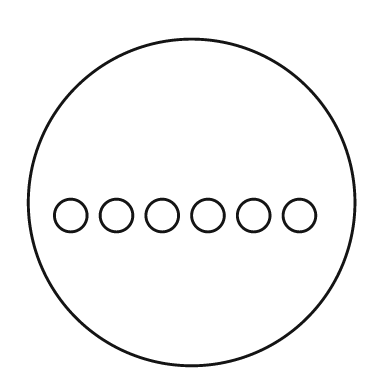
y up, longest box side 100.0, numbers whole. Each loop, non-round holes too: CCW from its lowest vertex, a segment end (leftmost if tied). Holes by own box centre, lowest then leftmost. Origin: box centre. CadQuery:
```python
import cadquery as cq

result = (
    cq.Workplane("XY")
    .moveTo(0.0, 0.0)
    .circle(50.0)
    .moveTo(-37.0, -4.0)
    .circle(5.0)
    .moveTo(-23.0, -4.0)
    .circle(5.0)
    .moveTo(-9.0, -4.0)
    .circle(5.0)
    .moveTo(5.0, -4.0)
    .circle(5.0)
    .moveTo(19.0, -4.0)
    .circle(5.0)
    .moveTo(33.0, -4.0)
    .circle(5.0)
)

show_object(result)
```